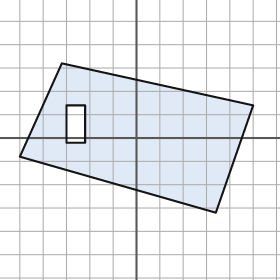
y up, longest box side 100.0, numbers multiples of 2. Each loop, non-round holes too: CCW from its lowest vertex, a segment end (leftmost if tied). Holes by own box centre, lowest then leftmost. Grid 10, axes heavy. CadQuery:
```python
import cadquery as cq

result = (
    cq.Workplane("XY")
    .moveTo(34.0, -32.0)
    .lineTo(50.0, 14.0)
    .lineTo(-32.0, 32.0)
    .lineTo(-50.0, -8.0)
    .close()
    .moveTo(-30.0, -2.0)
    .lineTo(-22.0, -2.0)
    .lineTo(-22.0, 14.0)
    .lineTo(-30.0, 14.0)
    .close()
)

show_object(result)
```